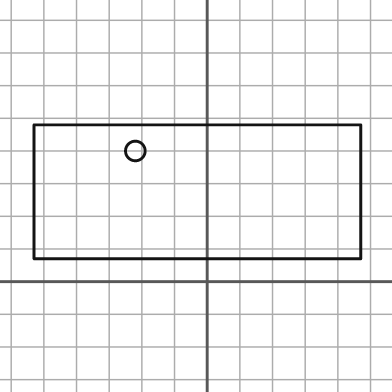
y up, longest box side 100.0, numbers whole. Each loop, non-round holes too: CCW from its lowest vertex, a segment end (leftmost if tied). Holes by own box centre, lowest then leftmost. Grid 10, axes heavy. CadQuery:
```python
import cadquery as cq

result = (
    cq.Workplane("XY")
    .moveTo(-53.0, 7.0)
    .lineTo(47.0, 7.0)
    .lineTo(47.0, 48.0)
    .lineTo(-53.0, 48.0)
    .close()
    .moveTo(-22.0, 40.0)
    .circle(3.0)
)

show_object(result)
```